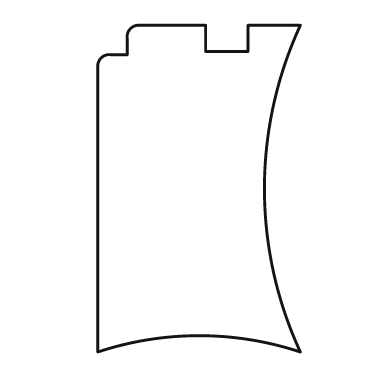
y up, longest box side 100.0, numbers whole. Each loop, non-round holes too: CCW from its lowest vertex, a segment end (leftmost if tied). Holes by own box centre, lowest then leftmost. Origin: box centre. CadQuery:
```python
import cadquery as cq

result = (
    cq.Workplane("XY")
    .moveTo(-31.0, -50.0)
    .threePointArc((0.0, -45.0), (31.0, -50.0))
    .threePointArc((20.0, 0.0), (31.0, 50.0))
    .lineTo(15.0, 50.0)
    .lineTo(15.0, 42.0)
    .lineTo(2.0, 42.0)
    .lineTo(2.0, 50.0)
    .lineTo(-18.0, 50.0)
    .threePointArc((-21.0, 49.0), (-22.0, 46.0))
    .lineTo(-22.0, 41.0)
    .lineTo(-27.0, 41.0)
    .threePointArc((-30.0, 40.0), (-31.0, 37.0))
    .close()
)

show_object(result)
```